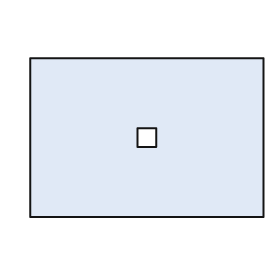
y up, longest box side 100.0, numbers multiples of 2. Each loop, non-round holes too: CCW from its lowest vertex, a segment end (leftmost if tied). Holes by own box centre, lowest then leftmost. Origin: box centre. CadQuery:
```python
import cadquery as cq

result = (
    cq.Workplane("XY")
    .moveTo(-50.0, -34.0)
    .lineTo(50.0, -34.0)
    .lineTo(50.0, 34.0)
    .lineTo(-50.0, 34.0)
    .close()
    .moveTo(-4.0, -4.0)
    .lineTo(4.0, -4.0)
    .lineTo(4.0, 4.0)
    .lineTo(-4.0, 4.0)
    .close()
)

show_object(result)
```